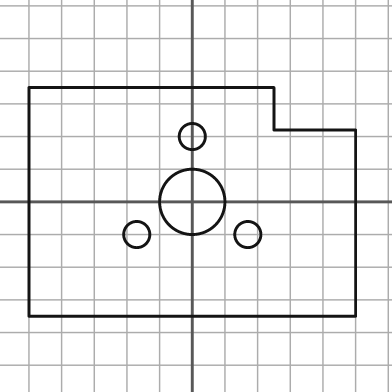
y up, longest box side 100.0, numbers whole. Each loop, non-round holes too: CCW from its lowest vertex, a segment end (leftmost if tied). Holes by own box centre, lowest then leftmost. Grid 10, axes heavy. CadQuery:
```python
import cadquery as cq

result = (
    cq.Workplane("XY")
    .moveTo(-50.0, -35.0)
    .lineTo(50.0, -35.0)
    .lineTo(50.0, 22.0)
    .lineTo(25.0, 22.0)
    .lineTo(25.0, 35.0)
    .lineTo(-50.0, 35.0)
    .close()
    .moveTo(-17.0, -10.0)
    .circle(4.0)
    .moveTo(17.0, -10.0)
    .circle(4.0)
    .moveTo(0.0, 0.0)
    .circle(10.0)
    .moveTo(0.0, 20.0)
    .circle(4.0)
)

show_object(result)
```